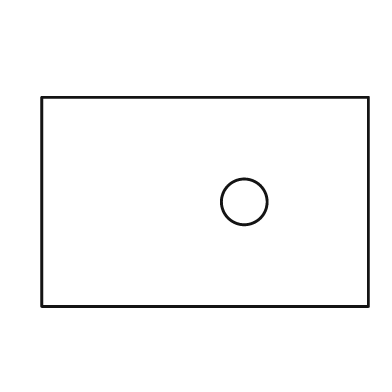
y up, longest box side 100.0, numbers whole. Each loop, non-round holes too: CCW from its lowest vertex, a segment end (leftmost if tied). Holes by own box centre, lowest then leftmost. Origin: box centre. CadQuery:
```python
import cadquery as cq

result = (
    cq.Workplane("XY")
    .moveTo(-50.0, -32.0)
    .lineTo(50.0, -32.0)
    .lineTo(50.0, 32.0)
    .lineTo(-50.0, 32.0)
    .close()
    .moveTo(12.0, 0.0)
    .circle(7.0)
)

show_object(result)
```